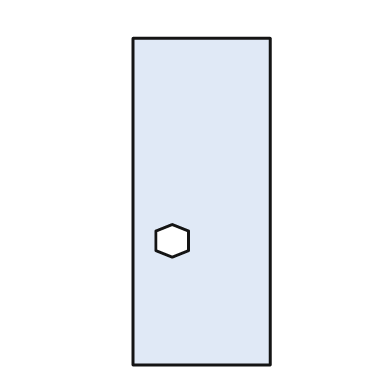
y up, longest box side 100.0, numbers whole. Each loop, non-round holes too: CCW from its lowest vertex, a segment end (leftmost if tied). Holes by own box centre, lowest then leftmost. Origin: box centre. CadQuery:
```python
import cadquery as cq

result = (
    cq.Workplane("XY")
    .moveTo(-21.0, -50.0)
    .lineTo(21.0, -50.0)
    .lineTo(21.0, 50.0)
    .lineTo(-21.0, 50.0)
    .close()
    .moveTo(-9.0, -17.0)
    .lineTo(-4.0, -15.0)
    .lineTo(-4.0, -9.0)
    .lineTo(-9.0, -7.0)
    .lineTo(-14.0, -9.0)
    .lineTo(-14.0, -15.0)
    .close()
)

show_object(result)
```